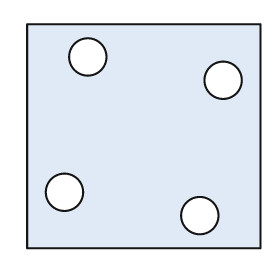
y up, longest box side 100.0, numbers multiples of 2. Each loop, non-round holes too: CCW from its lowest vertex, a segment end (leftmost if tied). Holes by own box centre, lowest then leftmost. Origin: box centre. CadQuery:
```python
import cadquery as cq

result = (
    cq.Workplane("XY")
    .moveTo(-50.0, -48.0)
    .lineTo(50.0, -48.0)
    .lineTo(50.0, 48.0)
    .lineTo(-50.0, 48.0)
    .close()
    .moveTo(24.0, -34.0)
    .circle(8.0)
    .moveTo(-34.0, -24.0)
    .circle(8.0)
    .moveTo(34.0, 24.0)
    .circle(8.0)
    .moveTo(-24.0, 34.0)
    .circle(8.0)
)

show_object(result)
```